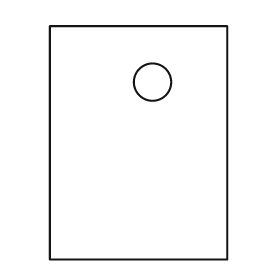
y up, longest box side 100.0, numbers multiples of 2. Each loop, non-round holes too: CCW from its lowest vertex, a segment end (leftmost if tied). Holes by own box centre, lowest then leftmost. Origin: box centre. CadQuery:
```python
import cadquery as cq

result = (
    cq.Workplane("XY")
    .moveTo(-38.0, -50.0)
    .lineTo(38.0, -50.0)
    .lineTo(38.0, 50.0)
    .lineTo(-38.0, 50.0)
    .close()
    .moveTo(6.0, 26.0)
    .circle(8.0)
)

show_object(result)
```